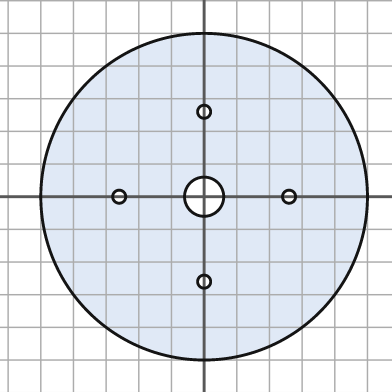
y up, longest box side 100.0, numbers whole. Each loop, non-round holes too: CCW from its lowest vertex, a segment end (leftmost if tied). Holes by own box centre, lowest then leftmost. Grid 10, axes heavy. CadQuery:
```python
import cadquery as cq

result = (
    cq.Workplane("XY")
    .moveTo(0.0, 0.0)
    .circle(50.0)
    .moveTo(0.0, -26.0)
    .circle(2.0)
    .moveTo(-26.0, 0.0)
    .circle(2.0)
    .moveTo(0.0, 0.0)
    .circle(6.0)
    .moveTo(26.0, 0.0)
    .circle(2.0)
    .moveTo(0.0, 26.0)
    .circle(2.0)
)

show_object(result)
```